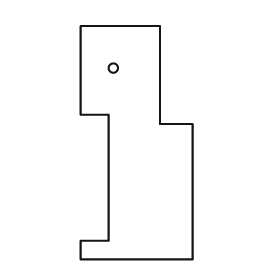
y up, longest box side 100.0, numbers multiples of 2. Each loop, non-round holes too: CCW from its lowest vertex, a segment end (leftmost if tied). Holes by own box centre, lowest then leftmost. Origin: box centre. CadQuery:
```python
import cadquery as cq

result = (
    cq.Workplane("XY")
    .moveTo(-24.0, -50.0)
    .lineTo(24.0, -50.0)
    .lineTo(24.0, 8.0)
    .lineTo(10.0, 8.0)
    .lineTo(10.0, 50.0)
    .lineTo(-24.0, 50.0)
    .lineTo(-24.0, 12.0)
    .lineTo(-12.0, 12.0)
    .lineTo(-12.0, -42.0)
    .lineTo(-24.0, -42.0)
    .close()
    .moveTo(-10.0, 32.0)
    .circle(2.0)
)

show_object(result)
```